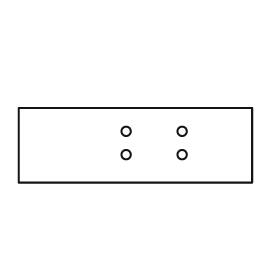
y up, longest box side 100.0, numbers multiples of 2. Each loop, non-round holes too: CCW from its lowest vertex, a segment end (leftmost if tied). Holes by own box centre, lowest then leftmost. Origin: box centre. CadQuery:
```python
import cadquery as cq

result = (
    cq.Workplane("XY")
    .moveTo(-50.0, -16.0)
    .lineTo(50.0, -16.0)
    .lineTo(50.0, 16.0)
    .lineTo(-50.0, 16.0)
    .close()
    .moveTo(-4.0, -4.0)
    .circle(2.0)
    .moveTo(20.0, -4.0)
    .circle(2.0)
    .moveTo(-4.0, 6.0)
    .circle(2.0)
    .moveTo(20.0, 6.0)
    .circle(2.0)
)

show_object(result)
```